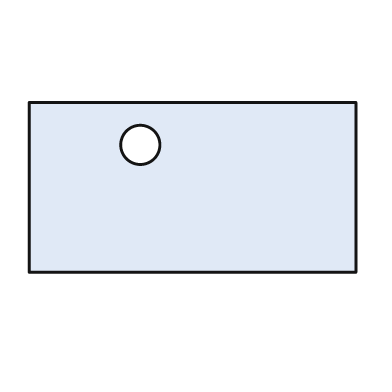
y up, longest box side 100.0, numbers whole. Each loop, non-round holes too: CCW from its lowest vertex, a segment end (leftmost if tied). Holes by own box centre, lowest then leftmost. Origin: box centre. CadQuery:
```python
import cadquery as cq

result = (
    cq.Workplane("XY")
    .moveTo(-50.0, -26.0)
    .lineTo(50.0, -26.0)
    .lineTo(50.0, 26.0)
    .lineTo(-50.0, 26.0)
    .close()
    .moveTo(-16.0, 13.0)
    .circle(6.0)
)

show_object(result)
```